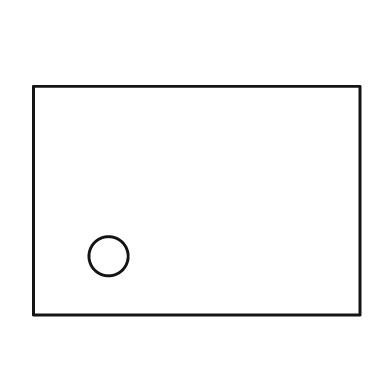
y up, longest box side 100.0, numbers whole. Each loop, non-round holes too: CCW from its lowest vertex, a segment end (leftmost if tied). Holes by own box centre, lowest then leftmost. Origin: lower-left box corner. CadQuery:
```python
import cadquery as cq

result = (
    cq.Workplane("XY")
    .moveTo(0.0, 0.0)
    .lineTo(100.0, 0.0)
    .lineTo(100.0, 70.0)
    .lineTo(0.0, 70.0)
    .close()
    .moveTo(23.0, 18.0)
    .circle(6.0)
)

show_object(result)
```